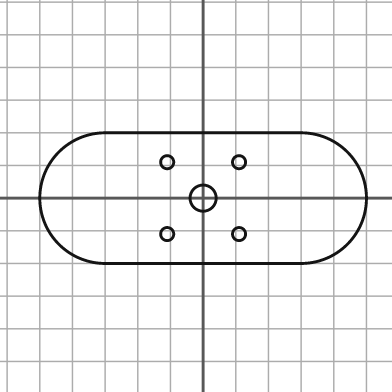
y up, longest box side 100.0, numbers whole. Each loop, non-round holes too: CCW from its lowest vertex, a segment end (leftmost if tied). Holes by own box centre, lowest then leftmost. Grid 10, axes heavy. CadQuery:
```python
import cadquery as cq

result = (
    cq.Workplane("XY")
    .moveTo(-30.0, -20.0)
    .lineTo(30.0, -20.0)
    .threePointArc((50.0, 0.0), (30.0, 20.0))
    .lineTo(-30.0, 20.0)
    .threePointArc((-50.0, 0.0), (-30.0, -20.0))
    .close()
    .moveTo(-11.0, -11.0)
    .circle(2.0)
    .moveTo(11.0, -11.0)
    .circle(2.0)
    .moveTo(0.0, 0.0)
    .circle(4.0)
    .moveTo(-11.0, 11.0)
    .circle(2.0)
    .moveTo(11.0, 11.0)
    .circle(2.0)
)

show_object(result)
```